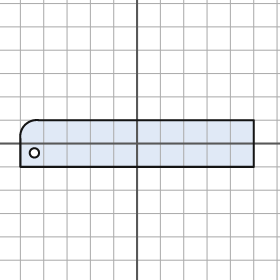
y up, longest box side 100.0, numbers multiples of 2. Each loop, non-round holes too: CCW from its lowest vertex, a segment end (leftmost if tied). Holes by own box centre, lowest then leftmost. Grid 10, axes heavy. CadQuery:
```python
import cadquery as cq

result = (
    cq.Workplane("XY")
    .moveTo(-50.0, -10.0)
    .lineTo(50.0, -10.0)
    .lineTo(50.0, 10.0)
    .lineTo(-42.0, 10.0)
    .threePointArc((-48.0, 8.0), (-50.0, 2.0))
    .close()
    .moveTo(-44.0, -4.0)
    .circle(2.0)
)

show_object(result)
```